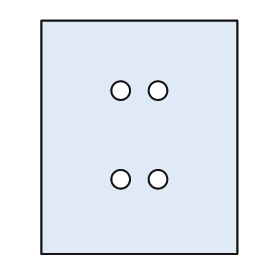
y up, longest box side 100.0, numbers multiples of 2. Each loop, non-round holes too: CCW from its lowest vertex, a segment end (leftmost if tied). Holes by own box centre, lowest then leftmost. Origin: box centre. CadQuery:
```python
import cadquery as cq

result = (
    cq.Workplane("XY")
    .moveTo(-42.0, -50.0)
    .lineTo(42.0, -50.0)
    .lineTo(42.0, 50.0)
    .lineTo(-42.0, 50.0)
    .close()
    .moveTo(-8.0, -18.0)
    .circle(4.0)
    .moveTo(8.0, -18.0)
    .circle(4.0)
    .moveTo(-8.0, 20.0)
    .circle(4.0)
    .moveTo(8.0, 20.0)
    .circle(4.0)
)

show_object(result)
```